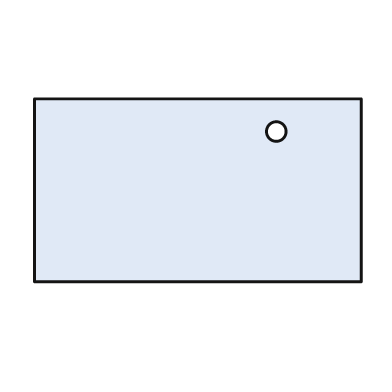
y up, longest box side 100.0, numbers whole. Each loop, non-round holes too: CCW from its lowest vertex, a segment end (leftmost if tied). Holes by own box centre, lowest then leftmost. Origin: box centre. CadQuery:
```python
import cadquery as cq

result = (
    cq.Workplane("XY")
    .moveTo(-50.0, -28.0)
    .lineTo(50.0, -28.0)
    .lineTo(50.0, 28.0)
    .lineTo(-50.0, 28.0)
    .close()
    .moveTo(24.0, 18.0)
    .circle(3.0)
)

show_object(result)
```